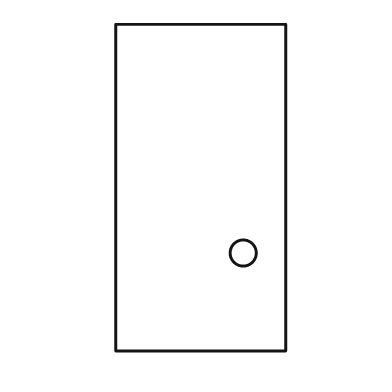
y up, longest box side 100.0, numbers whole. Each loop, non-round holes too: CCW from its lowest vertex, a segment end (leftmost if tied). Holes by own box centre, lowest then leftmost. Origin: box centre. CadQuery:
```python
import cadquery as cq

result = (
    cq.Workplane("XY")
    .moveTo(-26.0, -50.0)
    .lineTo(26.0, -50.0)
    .lineTo(26.0, 50.0)
    .lineTo(-26.0, 50.0)
    .close()
    .moveTo(13.0, -20.0)
    .circle(4.0)
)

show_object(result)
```